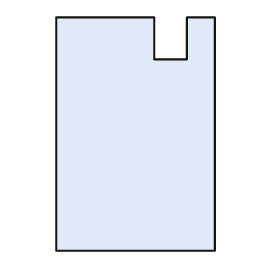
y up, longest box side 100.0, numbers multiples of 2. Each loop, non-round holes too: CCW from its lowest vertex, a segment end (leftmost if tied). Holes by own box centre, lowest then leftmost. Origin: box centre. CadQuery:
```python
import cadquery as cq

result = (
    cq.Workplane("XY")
    .moveTo(-34.0, -50.0)
    .lineTo(34.0, -50.0)
    .lineTo(34.0, 50.0)
    .lineTo(22.0, 50.0)
    .lineTo(22.0, 32.0)
    .lineTo(8.0, 32.0)
    .lineTo(8.0, 50.0)
    .lineTo(-34.0, 50.0)
    .close()
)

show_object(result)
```